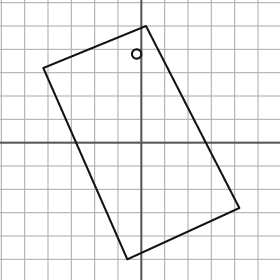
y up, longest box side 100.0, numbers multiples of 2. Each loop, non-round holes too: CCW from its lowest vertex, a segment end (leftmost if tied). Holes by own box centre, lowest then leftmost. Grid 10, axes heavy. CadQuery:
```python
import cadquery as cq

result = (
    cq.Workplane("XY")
    .moveTo(-6.0, -50.0)
    .lineTo(42.0, -28.0)
    .lineTo(2.0, 50.0)
    .lineTo(-42.0, 32.0)
    .close()
    .moveTo(-2.0, 38.0)
    .circle(2.0)
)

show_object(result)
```